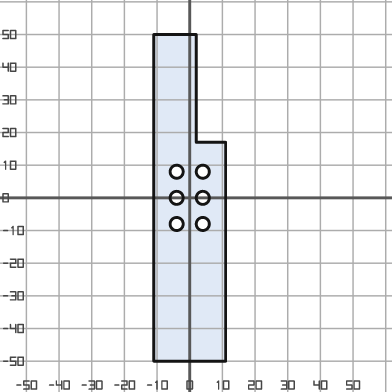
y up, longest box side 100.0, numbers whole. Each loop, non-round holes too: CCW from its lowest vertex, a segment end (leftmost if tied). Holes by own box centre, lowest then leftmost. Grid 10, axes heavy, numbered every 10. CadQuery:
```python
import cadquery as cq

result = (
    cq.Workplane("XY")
    .moveTo(-11.0, -50.0)
    .lineTo(11.0, -50.0)
    .lineTo(11.0, 17.0)
    .lineTo(2.0, 17.0)
    .lineTo(2.0, 50.0)
    .lineTo(-11.0, 50.0)
    .close()
    .moveTo(-4.0, -8.0)
    .circle(2.0)
    .moveTo(4.0, -8.0)
    .circle(2.0)
    .moveTo(-4.0, 0.0)
    .circle(2.0)
    .moveTo(4.0, 0.0)
    .circle(2.0)
    .moveTo(-4.0, 8.0)
    .circle(2.0)
    .moveTo(4.0, 8.0)
    .circle(2.0)
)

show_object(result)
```